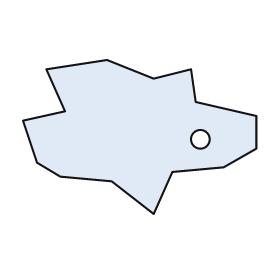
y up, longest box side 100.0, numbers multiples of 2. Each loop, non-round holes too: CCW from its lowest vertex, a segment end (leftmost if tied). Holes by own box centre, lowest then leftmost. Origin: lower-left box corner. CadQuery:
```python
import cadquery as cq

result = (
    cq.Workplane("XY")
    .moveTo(56.0, 0.0)
    .lineTo(64.0, 18.0)
    .lineTo(86.0, 20.0)
    .lineTo(100.0, 28.0)
    .lineTo(100.0, 42.0)
    .lineTo(74.0, 48.0)
    .lineTo(72.0, 62.0)
    .lineTo(56.0, 58.0)
    .lineTo(36.0, 66.0)
    .lineTo(10.0, 62.0)
    .lineTo(18.0, 44.0)
    .lineTo(0.0, 40.0)
    .lineTo(6.0, 22.0)
    .lineTo(16.0, 16.0)
    .lineTo(38.0, 14.0)
    .close()
    .moveTo(76.0, 32.0)
    .circle(4.0)
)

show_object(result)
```